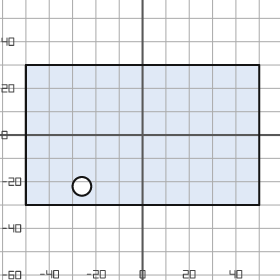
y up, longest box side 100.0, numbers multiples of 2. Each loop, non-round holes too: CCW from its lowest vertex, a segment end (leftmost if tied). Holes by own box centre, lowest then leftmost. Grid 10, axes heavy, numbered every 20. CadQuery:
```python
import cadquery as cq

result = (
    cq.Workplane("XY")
    .moveTo(-50.0, -30.0)
    .lineTo(50.0, -30.0)
    .lineTo(50.0, 30.0)
    .lineTo(-50.0, 30.0)
    .close()
    .moveTo(-26.0, -22.0)
    .circle(4.0)
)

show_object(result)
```